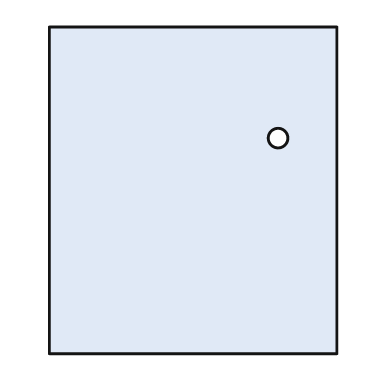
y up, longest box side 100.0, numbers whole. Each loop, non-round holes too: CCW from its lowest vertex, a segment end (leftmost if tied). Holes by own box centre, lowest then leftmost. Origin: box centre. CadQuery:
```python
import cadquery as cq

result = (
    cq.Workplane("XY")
    .moveTo(-44.0, -50.0)
    .lineTo(44.0, -50.0)
    .lineTo(44.0, 50.0)
    .lineTo(-44.0, 50.0)
    .close()
    .moveTo(26.0, 16.0)
    .circle(3.0)
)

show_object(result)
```